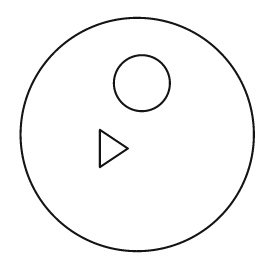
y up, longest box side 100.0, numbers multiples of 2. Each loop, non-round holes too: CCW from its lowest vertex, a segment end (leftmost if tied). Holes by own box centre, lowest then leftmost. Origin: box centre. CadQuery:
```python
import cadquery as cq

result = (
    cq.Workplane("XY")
    .moveTo(0.0, 0.0)
    .circle(50.0)
    .moveTo(-16.0, -14.0)
    .lineTo(-4.0, -6.0)
    .lineTo(-16.0, 2.0)
    .close()
    .moveTo(2.0, 22.0)
    .circle(12.0)
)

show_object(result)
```